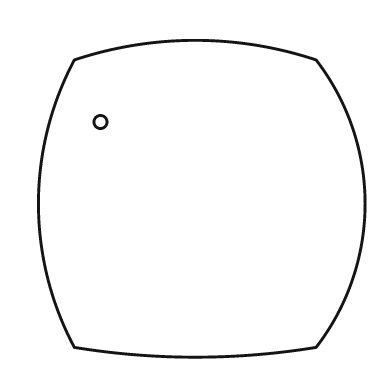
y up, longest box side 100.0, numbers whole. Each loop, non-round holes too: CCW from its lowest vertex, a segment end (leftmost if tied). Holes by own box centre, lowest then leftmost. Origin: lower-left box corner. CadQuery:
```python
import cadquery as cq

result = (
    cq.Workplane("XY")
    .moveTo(11.0, 3.0)
    .threePointArc((48.0, 0.0), (85.0, 3.0))
    .threePointArc((100.0, 47.0), (85.0, 91.0))
    .threePointArc((48.0, 97.0), (11.0, 91.0))
    .threePointArc((0.0, 47.0), (11.0, 3.0))
    .close()
    .moveTo(19.0, 72.0)
    .circle(2.0)
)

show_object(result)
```